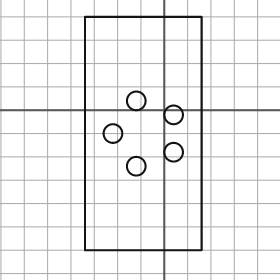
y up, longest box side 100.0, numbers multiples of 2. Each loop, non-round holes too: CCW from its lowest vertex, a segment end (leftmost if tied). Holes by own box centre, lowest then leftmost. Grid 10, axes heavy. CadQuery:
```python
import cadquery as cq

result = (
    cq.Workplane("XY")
    .moveTo(-34.0, -60.0)
    .lineTo(16.0, -60.0)
    .lineTo(16.0, 40.0)
    .lineTo(-34.0, 40.0)
    .close()
    .moveTo(-12.0, -24.0)
    .circle(4.0)
    .moveTo(4.0, -18.0)
    .circle(4.0)
    .moveTo(-22.0, -10.0)
    .circle(4.0)
    .moveTo(4.0, -2.0)
    .circle(4.0)
    .moveTo(-12.0, 4.0)
    .circle(4.0)
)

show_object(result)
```